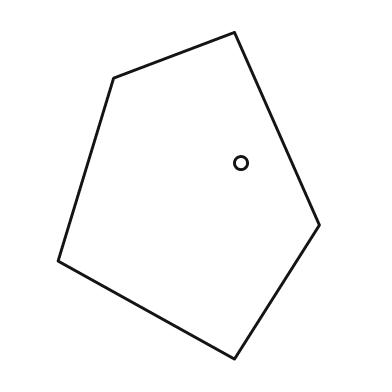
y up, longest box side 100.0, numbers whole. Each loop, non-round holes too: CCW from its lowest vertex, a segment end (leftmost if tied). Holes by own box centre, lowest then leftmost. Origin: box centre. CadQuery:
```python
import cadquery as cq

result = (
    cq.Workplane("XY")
    .moveTo(14.0, -50.0)
    .lineTo(40.0, -9.0)
    .lineTo(14.0, 50.0)
    .lineTo(-23.0, 36.0)
    .lineTo(-40.0, -20.0)
    .close()
    .moveTo(16.0, 10.0)
    .circle(2.0)
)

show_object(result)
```